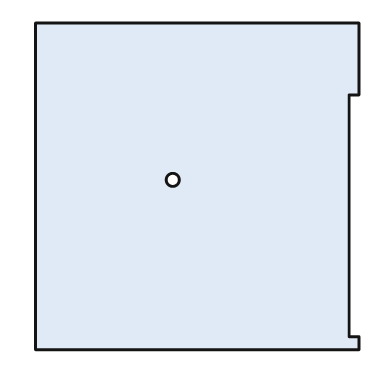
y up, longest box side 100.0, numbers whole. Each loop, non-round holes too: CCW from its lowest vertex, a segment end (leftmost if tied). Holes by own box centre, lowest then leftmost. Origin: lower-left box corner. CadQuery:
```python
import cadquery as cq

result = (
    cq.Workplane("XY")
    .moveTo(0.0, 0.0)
    .lineTo(99.0, 0.0)
    .lineTo(99.0, 4.0)
    .lineTo(96.0, 4.0)
    .lineTo(96.0, 78.0)
    .lineTo(99.0, 78.0)
    .lineTo(99.0, 100.0)
    .lineTo(0.0, 100.0)
    .close()
    .moveTo(42.0, 52.0)
    .circle(2.0)
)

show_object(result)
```